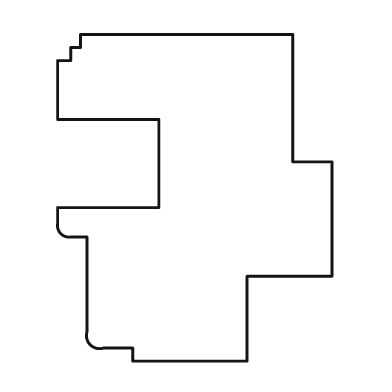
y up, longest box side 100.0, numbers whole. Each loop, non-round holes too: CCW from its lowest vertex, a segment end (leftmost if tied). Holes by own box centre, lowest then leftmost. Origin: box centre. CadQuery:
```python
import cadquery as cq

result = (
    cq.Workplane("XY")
    .moveTo(-19.0, -50.0)
    .lineTo(16.0, -50.0)
    .lineTo(16.0, -24.0)
    .lineTo(42.0, -24.0)
    .lineTo(42.0, 11.0)
    .lineTo(30.0, 11.0)
    .lineTo(30.0, 50.0)
    .lineTo(-35.0, 50.0)
    .lineTo(-35.0, 46.0)
    .lineTo(-38.0, 46.0)
    .lineTo(-38.0, 42.0)
    .lineTo(-42.0, 42.0)
    .lineTo(-42.0, 24.0)
    .lineTo(-11.0, 24.0)
    .lineTo(-11.0, -3.0)
    .lineTo(-42.0, -3.0)
    .lineTo(-42.0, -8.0)
    .threePointArc((-41.0, -11.0), (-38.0, -12.0))
    .lineTo(-33.0, -12.0)
    .lineTo(-33.0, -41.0)
    .threePointArc((-32.0, -45.0), (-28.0, -46.0))
    .lineTo(-19.0, -46.0)
    .close()
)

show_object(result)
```